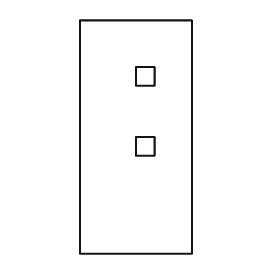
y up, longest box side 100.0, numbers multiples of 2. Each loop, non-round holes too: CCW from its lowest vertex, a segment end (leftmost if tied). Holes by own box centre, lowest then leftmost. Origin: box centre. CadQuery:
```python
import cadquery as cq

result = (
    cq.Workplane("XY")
    .moveTo(-24.0, -50.0)
    .lineTo(24.0, -50.0)
    .lineTo(24.0, 50.0)
    .lineTo(-24.0, 50.0)
    .close()
    .moveTo(0.0, -8.0)
    .lineTo(8.0, -8.0)
    .lineTo(8.0, 0.0)
    .lineTo(0.0, 0.0)
    .close()
    .moveTo(0.0, 22.0)
    .lineTo(8.0, 22.0)
    .lineTo(8.0, 30.0)
    .lineTo(0.0, 30.0)
    .close()
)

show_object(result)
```